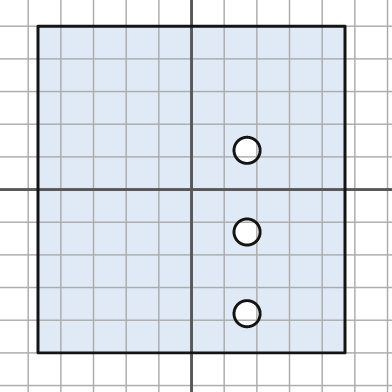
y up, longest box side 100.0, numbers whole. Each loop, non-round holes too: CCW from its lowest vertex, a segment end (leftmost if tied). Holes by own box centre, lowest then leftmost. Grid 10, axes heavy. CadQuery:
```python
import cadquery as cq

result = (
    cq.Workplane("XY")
    .moveTo(-47.0, -50.0)
    .lineTo(47.0, -50.0)
    .lineTo(47.0, 50.0)
    .lineTo(-47.0, 50.0)
    .close()
    .moveTo(17.0, -38.0)
    .circle(4.0)
    .moveTo(17.0, -13.0)
    .circle(4.0)
    .moveTo(17.0, 12.0)
    .circle(4.0)
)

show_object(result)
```